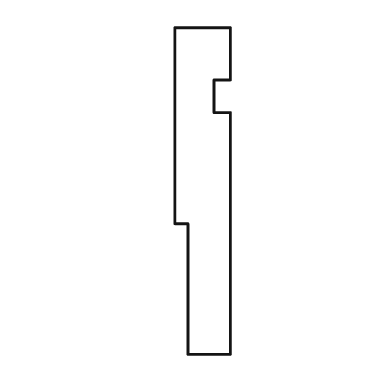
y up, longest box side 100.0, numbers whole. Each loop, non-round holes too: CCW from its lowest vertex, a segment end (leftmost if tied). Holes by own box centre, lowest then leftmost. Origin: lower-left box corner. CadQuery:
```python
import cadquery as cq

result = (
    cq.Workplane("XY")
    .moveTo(4.0, 0.0)
    .lineTo(17.0, 0.0)
    .lineTo(17.0, 74.0)
    .lineTo(12.0, 74.0)
    .lineTo(12.0, 84.0)
    .lineTo(17.0, 84.0)
    .lineTo(17.0, 100.0)
    .lineTo(0.0, 100.0)
    .lineTo(0.0, 40.0)
    .lineTo(4.0, 40.0)
    .close()
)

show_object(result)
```